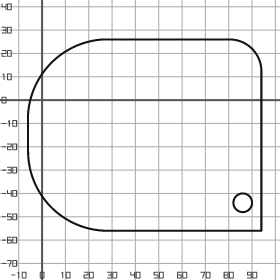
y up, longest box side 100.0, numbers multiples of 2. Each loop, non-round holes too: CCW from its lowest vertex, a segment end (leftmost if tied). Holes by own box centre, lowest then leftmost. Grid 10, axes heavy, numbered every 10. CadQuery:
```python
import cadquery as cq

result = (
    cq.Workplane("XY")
    .moveTo(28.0, -56.0)
    .lineTo(94.0, -56.0)
    .lineTo(94.0, 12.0)
    .threePointArc((90.0, 22.0), (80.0, 26.0))
    .lineTo(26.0, 26.0)
    .threePointArc((4.0, 16.0), (-6.0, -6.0))
    .lineTo(-6.0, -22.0)
    .threePointArc((4.0, -46.0), (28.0, -56.0))
    .close()
    .moveTo(86.0, -44.0)
    .circle(4.0)
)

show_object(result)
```